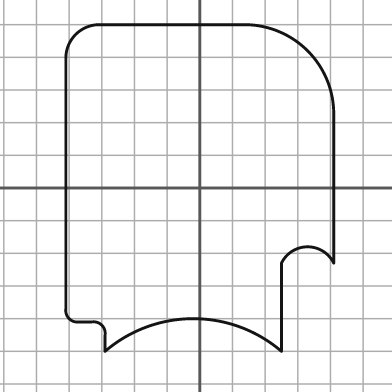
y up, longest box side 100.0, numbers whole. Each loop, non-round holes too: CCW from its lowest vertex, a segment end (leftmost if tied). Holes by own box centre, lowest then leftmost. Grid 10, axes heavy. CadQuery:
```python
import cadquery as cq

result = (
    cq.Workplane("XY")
    .moveTo(-29.0, -50.0)
    .threePointArc((-2.0, -40.0), (25.0, -50.0))
    .lineTo(25.0, -23.0)
    .threePointArc((33.0, -18.0), (41.0, -23.0))
    .lineTo(41.0, 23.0)
    .threePointArc((33.0, 42.0), (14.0, 50.0))
    .lineTo(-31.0, 50.0)
    .threePointArc((-38.0, 47.0), (-41.0, 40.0))
    .lineTo(-41.0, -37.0)
    .threePointArc((-40.0, -40.0), (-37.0, -41.0))
    .lineTo(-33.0, -41.0)
    .threePointArc((-30.0, -42.0), (-29.0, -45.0))
    .close()
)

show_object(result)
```